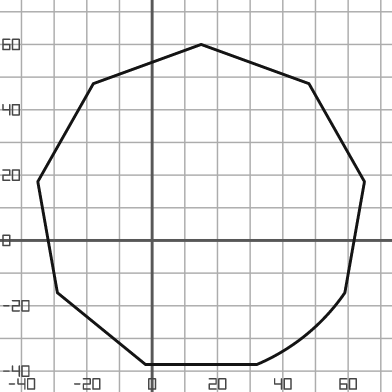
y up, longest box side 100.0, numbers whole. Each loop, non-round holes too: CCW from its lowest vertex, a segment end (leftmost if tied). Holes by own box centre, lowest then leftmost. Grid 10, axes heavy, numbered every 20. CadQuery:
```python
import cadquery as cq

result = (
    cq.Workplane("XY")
    .moveTo(-2.0, -38.0)
    .lineTo(32.0, -38.0)
    .threePointArc((47.0, -29.0), (59.0, -16.0))
    .lineTo(65.0, 18.0)
    .lineTo(48.0, 48.0)
    .lineTo(15.0, 60.0)
    .lineTo(-18.0, 48.0)
    .lineTo(-35.0, 18.0)
    .lineTo(-29.0, -16.0)
    .close()
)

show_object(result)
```